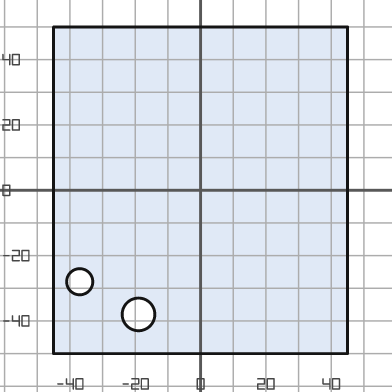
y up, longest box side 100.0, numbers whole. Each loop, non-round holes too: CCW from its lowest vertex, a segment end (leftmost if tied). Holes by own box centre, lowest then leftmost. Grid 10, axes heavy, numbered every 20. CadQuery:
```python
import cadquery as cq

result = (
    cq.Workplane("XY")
    .moveTo(-45.0, -50.0)
    .lineTo(45.0, -50.0)
    .lineTo(45.0, 50.0)
    .lineTo(-45.0, 50.0)
    .close()
    .moveTo(-19.0, -38.0)
    .circle(5.0)
    .moveTo(-37.0, -28.0)
    .circle(4.0)
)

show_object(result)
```